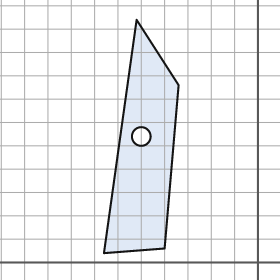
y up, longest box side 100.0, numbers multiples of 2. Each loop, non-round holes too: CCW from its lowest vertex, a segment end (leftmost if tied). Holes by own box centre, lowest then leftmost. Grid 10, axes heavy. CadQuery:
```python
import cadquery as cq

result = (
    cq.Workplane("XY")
    .moveTo(-66.0, 4.0)
    .lineTo(-40.0, 6.0)
    .lineTo(-34.0, 76.0)
    .lineTo(-52.0, 104.0)
    .close()
    .moveTo(-50.0, 54.0)
    .circle(4.0)
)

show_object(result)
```